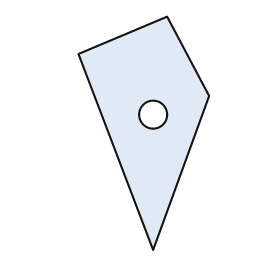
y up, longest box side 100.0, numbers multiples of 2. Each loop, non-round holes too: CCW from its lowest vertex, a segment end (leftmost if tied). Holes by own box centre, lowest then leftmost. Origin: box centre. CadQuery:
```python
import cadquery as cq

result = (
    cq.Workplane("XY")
    .moveTo(4.0, -50.0)
    .lineTo(28.0, 16.0)
    .lineTo(10.0, 50.0)
    .lineTo(-28.0, 34.0)
    .close()
    .moveTo(4.0, 8.0)
    .circle(6.0)
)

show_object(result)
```